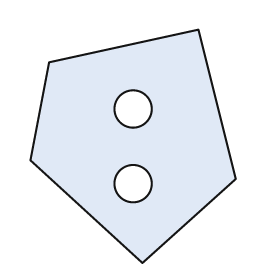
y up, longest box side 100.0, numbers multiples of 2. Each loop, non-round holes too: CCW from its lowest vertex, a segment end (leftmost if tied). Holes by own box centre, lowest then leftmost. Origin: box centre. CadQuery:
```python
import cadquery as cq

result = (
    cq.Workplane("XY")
    .moveTo(4.0, -50.0)
    .lineTo(44.0, -14.0)
    .lineTo(28.0, 50.0)
    .lineTo(-36.0, 36.0)
    .lineTo(-44.0, -6.0)
    .close()
    .moveTo(0.0, -16.0)
    .circle(8.0)
    .moveTo(0.0, 16.0)
    .circle(8.0)
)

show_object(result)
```